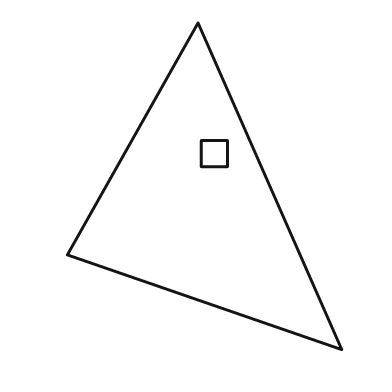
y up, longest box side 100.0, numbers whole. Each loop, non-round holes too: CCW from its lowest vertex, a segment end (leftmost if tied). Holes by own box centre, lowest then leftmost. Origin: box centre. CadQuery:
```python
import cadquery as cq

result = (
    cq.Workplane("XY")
    .moveTo(42.0, -50.0)
    .lineTo(-2.0, 50.0)
    .lineTo(-42.0, -21.0)
    .close()
    .moveTo(-1.0, 6.0)
    .lineTo(7.0, 6.0)
    .lineTo(7.0, 14.0)
    .lineTo(-1.0, 14.0)
    .close()
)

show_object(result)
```